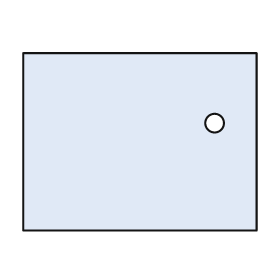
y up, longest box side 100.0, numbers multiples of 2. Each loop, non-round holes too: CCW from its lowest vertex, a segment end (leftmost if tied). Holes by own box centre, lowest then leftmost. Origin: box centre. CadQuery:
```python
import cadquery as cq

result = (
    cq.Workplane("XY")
    .moveTo(-50.0, -38.0)
    .lineTo(50.0, -38.0)
    .lineTo(50.0, 38.0)
    .lineTo(-50.0, 38.0)
    .close()
    .moveTo(32.0, 8.0)
    .circle(4.0)
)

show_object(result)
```